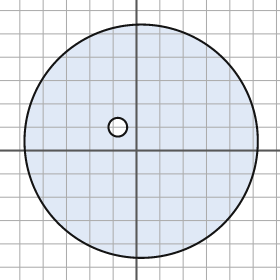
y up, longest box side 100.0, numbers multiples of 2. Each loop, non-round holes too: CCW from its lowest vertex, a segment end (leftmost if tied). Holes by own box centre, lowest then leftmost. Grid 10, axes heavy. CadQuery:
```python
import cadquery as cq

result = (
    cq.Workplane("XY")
    .moveTo(2.0, 4.0)
    .circle(50.0)
    .moveTo(-8.0, 10.0)
    .circle(4.0)
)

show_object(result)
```